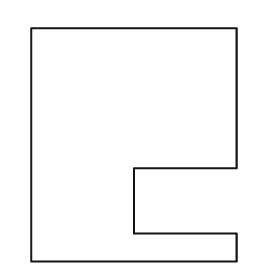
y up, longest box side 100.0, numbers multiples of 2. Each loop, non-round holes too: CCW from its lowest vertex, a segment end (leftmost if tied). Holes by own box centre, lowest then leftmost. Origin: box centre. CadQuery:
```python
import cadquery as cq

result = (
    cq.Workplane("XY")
    .moveTo(-44.0, -50.0)
    .lineTo(44.0, -50.0)
    .lineTo(44.0, -38.0)
    .lineTo(0.0, -38.0)
    .lineTo(0.0, -10.0)
    .lineTo(44.0, -10.0)
    .lineTo(44.0, 50.0)
    .lineTo(-44.0, 50.0)
    .close()
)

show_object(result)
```